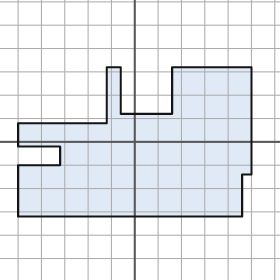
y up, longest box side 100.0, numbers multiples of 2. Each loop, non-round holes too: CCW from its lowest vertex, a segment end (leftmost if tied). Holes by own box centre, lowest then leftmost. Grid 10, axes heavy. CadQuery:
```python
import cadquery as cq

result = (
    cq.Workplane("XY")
    .moveTo(-50.0, -32.0)
    .lineTo(46.0, -32.0)
    .lineTo(46.0, -14.0)
    .lineTo(50.0, -14.0)
    .lineTo(50.0, 32.0)
    .lineTo(16.0, 32.0)
    .lineTo(16.0, 12.0)
    .lineTo(-6.0, 12.0)
    .lineTo(-6.0, 32.0)
    .lineTo(-12.0, 32.0)
    .lineTo(-12.0, 8.0)
    .lineTo(-50.0, 8.0)
    .lineTo(-50.0, -2.0)
    .lineTo(-32.0, -2.0)
    .lineTo(-32.0, -10.0)
    .lineTo(-50.0, -10.0)
    .close()
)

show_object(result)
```